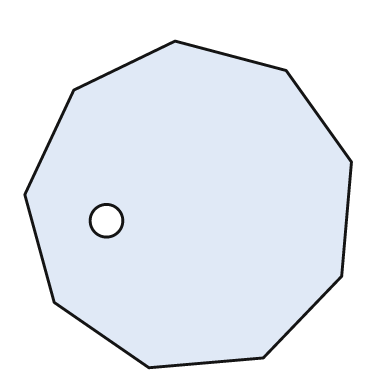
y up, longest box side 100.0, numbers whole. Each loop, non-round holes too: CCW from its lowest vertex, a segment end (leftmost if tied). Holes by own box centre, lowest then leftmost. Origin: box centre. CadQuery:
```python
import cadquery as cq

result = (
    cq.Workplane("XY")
    .moveTo(-12.0, -50.0)
    .lineTo(23.0, -47.0)
    .lineTo(47.0, -22.0)
    .lineTo(50.0, 13.0)
    .lineTo(30.0, 41.0)
    .lineTo(-4.0, 50.0)
    .lineTo(-35.0, 35.0)
    .lineTo(-50.0, 3.0)
    .lineTo(-41.0, -30.0)
    .close()
    .moveTo(-25.0, -5.0)
    .circle(5.0)
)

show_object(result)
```